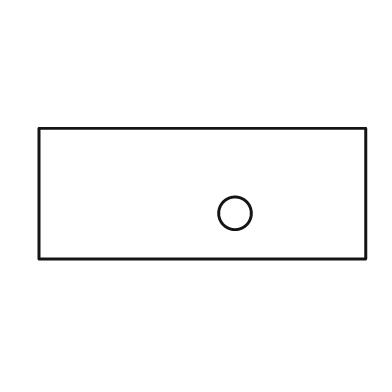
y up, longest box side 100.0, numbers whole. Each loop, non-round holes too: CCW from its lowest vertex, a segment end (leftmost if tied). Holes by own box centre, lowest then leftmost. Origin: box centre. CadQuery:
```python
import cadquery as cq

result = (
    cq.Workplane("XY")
    .moveTo(-50.0, -20.0)
    .lineTo(50.0, -20.0)
    .lineTo(50.0, 20.0)
    .lineTo(-50.0, 20.0)
    .close()
    .moveTo(10.0, -6.0)
    .circle(5.0)
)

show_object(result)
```